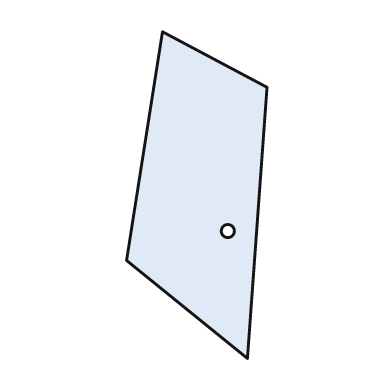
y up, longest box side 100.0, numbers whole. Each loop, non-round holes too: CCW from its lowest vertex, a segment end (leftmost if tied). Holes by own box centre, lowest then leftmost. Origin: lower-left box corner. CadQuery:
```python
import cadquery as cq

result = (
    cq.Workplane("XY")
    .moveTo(37.0, 0.0)
    .lineTo(43.0, 83.0)
    .lineTo(11.0, 100.0)
    .lineTo(0.0, 30.0)
    .close()
    .moveTo(31.0, 39.0)
    .circle(2.0)
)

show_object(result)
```